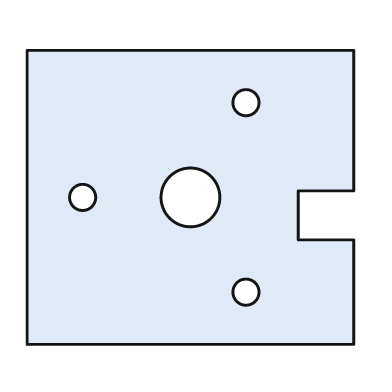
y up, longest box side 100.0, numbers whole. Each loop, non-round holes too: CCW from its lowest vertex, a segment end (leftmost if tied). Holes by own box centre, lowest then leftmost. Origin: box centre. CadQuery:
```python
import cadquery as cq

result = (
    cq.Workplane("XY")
    .moveTo(-50.0, -45.0)
    .lineTo(50.0, -45.0)
    .lineTo(50.0, -13.0)
    .lineTo(33.0, -13.0)
    .lineTo(33.0, 2.0)
    .lineTo(50.0, 2.0)
    .lineTo(50.0, 45.0)
    .lineTo(-50.0, 45.0)
    .close()
    .moveTo(17.0, -29.0)
    .circle(4.0)
    .moveTo(-33.0, 0.0)
    .circle(4.0)
    .moveTo(0.0, 0.0)
    .circle(9.0)
    .moveTo(17.0, 29.0)
    .circle(4.0)
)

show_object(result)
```